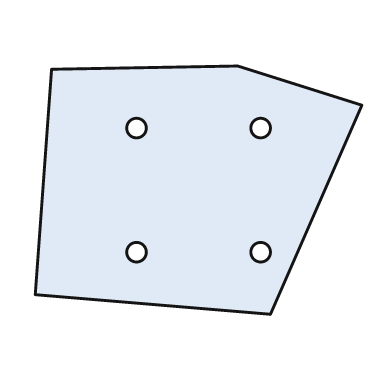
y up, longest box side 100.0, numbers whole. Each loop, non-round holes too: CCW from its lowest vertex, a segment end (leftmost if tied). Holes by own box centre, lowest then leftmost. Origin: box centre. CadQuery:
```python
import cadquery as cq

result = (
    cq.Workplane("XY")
    .moveTo(22.0, -38.0)
    .lineTo(50.0, 26.0)
    .lineTo(12.0, 38.0)
    .lineTo(-45.0, 37.0)
    .lineTo(-50.0, -32.0)
    .close()
    .moveTo(-19.0, -19.0)
    .circle(3.0)
    .moveTo(19.0, -19.0)
    .circle(3.0)
    .moveTo(-19.0, 19.0)
    .circle(3.0)
    .moveTo(19.0, 19.0)
    .circle(3.0)
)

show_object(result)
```